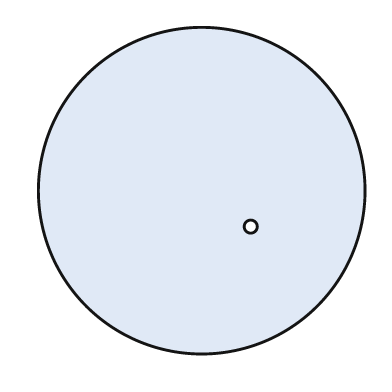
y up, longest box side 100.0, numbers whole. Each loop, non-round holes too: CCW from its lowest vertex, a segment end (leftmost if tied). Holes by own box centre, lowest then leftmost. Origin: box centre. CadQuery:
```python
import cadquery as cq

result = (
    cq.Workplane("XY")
    .moveTo(0.0, 0.0)
    .circle(50.0)
    .moveTo(15.0, -11.0)
    .circle(2.0)
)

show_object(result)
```